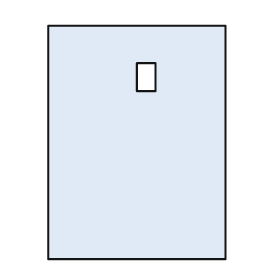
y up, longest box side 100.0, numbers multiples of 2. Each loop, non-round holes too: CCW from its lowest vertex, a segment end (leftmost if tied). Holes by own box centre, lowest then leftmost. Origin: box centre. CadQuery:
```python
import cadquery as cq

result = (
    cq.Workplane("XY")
    .moveTo(-38.0, -50.0)
    .lineTo(38.0, -50.0)
    .lineTo(38.0, 50.0)
    .lineTo(-38.0, 50.0)
    .close()
    .moveTo(0.0, 22.0)
    .lineTo(8.0, 22.0)
    .lineTo(8.0, 34.0)
    .lineTo(0.0, 34.0)
    .close()
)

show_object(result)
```